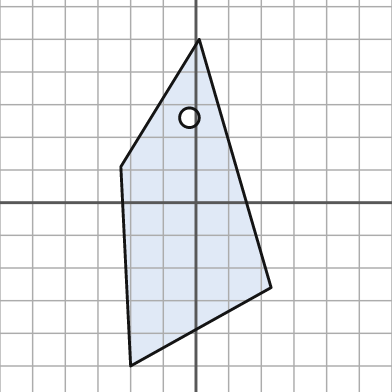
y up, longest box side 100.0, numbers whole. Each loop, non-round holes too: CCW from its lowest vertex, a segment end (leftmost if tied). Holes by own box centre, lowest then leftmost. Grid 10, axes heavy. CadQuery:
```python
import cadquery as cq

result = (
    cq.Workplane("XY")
    .moveTo(-20.0, -50.0)
    .lineTo(23.0, -26.0)
    .lineTo(1.0, 50.0)
    .lineTo(-23.0, 11.0)
    .close()
    .moveTo(-2.0, 26.0)
    .circle(3.0)
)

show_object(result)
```